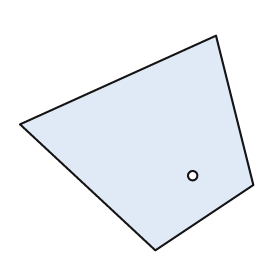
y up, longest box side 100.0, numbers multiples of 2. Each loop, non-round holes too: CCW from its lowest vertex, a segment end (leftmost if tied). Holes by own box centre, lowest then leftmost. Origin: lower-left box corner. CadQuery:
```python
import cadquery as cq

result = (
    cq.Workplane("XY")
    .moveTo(58.0, 0.0)
    .lineTo(100.0, 28.0)
    .lineTo(84.0, 92.0)
    .lineTo(0.0, 54.0)
    .close()
    .moveTo(74.0, 32.0)
    .circle(2.0)
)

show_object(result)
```